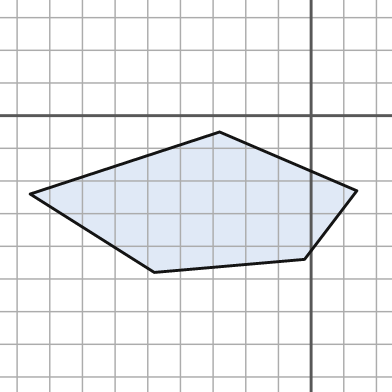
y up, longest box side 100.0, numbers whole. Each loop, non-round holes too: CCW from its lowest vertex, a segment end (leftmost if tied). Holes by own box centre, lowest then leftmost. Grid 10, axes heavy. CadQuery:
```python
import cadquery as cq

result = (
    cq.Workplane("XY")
    .moveTo(-48.0, -48.0)
    .lineTo(-2.0, -44.0)
    .lineTo(14.0, -23.0)
    .lineTo(-28.0, -5.0)
    .lineTo(-86.0, -24.0)
    .close()
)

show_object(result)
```